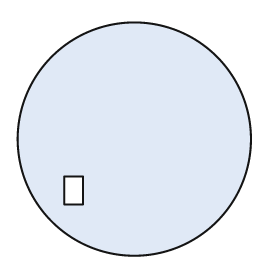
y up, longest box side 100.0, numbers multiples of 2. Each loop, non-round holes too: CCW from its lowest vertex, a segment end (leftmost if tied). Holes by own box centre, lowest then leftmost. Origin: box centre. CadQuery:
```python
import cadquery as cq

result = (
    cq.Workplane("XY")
    .moveTo(0.0, 0.0)
    .circle(50.0)
    .moveTo(-30.0, -28.0)
    .lineTo(-22.0, -28.0)
    .lineTo(-22.0, -16.0)
    .lineTo(-30.0, -16.0)
    .close()
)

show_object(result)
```